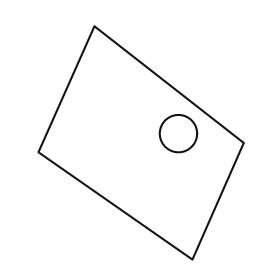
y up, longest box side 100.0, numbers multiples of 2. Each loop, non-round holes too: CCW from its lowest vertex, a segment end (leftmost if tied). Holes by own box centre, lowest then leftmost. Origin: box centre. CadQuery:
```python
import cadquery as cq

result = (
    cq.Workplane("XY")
    .moveTo(22.0, -50.0)
    .lineTo(44.0, 0.0)
    .lineTo(-20.0, 50.0)
    .lineTo(-44.0, -4.0)
    .close()
    .moveTo(16.0, 4.0)
    .circle(8.0)
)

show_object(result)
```